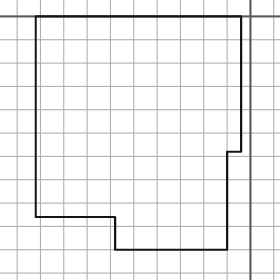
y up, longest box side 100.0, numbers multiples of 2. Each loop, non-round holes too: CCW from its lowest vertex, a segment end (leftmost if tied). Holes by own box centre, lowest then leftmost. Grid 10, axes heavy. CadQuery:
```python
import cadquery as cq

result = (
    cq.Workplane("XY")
    .moveTo(-58.0, -100.0)
    .lineTo(-10.0, -100.0)
    .lineTo(-10.0, -58.0)
    .lineTo(-4.0, -58.0)
    .lineTo(-4.0, 0.0)
    .lineTo(-92.0, 0.0)
    .lineTo(-92.0, -86.0)
    .lineTo(-58.0, -86.0)
    .close()
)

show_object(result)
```